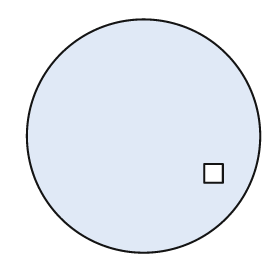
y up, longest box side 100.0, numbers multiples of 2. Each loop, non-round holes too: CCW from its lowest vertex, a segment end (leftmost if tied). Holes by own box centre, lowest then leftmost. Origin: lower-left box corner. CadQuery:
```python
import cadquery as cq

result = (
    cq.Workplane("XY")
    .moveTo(50.0, 50.0)
    .circle(50.0)
    .moveTo(76.0, 30.0)
    .lineTo(84.0, 30.0)
    .lineTo(84.0, 38.0)
    .lineTo(76.0, 38.0)
    .close()
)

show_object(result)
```